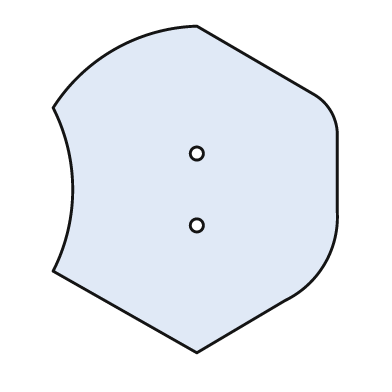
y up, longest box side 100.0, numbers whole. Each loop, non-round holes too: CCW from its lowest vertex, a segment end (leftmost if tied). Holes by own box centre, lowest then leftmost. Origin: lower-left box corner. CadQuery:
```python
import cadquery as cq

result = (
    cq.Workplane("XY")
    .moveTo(44.0, 0.0)
    .lineTo(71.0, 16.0)
    .threePointArc((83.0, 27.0), (87.0, 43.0))
    .lineTo(87.0, 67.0)
    .threePointArc((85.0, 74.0), (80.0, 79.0))
    .lineTo(44.0, 100.0)
    .threePointArc((19.0, 93.0), (0.0, 75.0))
    .threePointArc((6.0, 50.0), (0.0, 25.0))
    .close()
    .moveTo(44.0, 39.0)
    .circle(2.0)
    .moveTo(44.0, 61.0)
    .circle(2.0)
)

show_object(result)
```